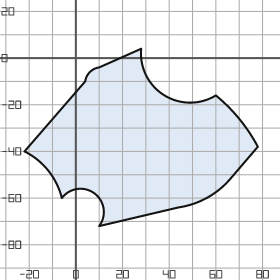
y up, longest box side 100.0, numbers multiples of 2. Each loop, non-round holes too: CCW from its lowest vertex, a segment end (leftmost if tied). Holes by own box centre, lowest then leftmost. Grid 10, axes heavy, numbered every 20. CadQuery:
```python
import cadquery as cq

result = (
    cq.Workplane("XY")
    .moveTo(10.0, -72.0)
    .lineTo(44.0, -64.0)
    .threePointArc((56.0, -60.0), (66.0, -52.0))
    .lineTo(78.0, -38.0)
    .threePointArc((70.0, -26.0), (60.0, -16.0))
    .threePointArc((38.0, -16.0), (28.0, 4.0))
    .lineTo(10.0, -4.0)
    .threePointArc((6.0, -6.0), (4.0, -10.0))
    .lineTo(-22.0, -40.0)
    .threePointArc((-12.0, -48.0), (-6.0, -60.0))
    .threePointArc((8.0, -58.0), (10.0, -72.0))
    .close()
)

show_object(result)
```